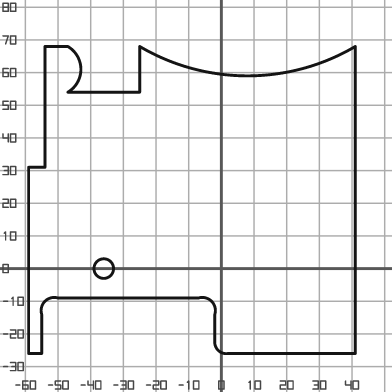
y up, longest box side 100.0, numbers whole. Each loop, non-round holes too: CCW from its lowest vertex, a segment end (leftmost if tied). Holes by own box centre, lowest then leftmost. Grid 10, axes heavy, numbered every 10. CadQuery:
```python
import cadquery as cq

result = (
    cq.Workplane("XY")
    .moveTo(-59.0, -26.0)
    .lineTo(-55.0, -26.0)
    .lineTo(-55.0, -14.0)
    .threePointArc((-54.0, -10.0), (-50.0, -9.0))
    .lineTo(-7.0, -9.0)
    .threePointArc((-3.0, -10.0), (-2.0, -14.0))
    .lineTo(-2.0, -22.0)
    .threePointArc((-1.0, -25.0), (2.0, -26.0))
    .lineTo(41.0, -26.0)
    .lineTo(41.0, 68.0)
    .threePointArc((8.0, 59.0), (-25.0, 68.0))
    .lineTo(-25.0, 54.0)
    .lineTo(-47.0, 54.0)
    .threePointArc((-43.0, 61.0), (-47.0, 68.0))
    .lineTo(-54.0, 68.0)
    .lineTo(-54.0, 31.0)
    .lineTo(-59.0, 31.0)
    .close()
    .moveTo(-36.0, 0.0)
    .circle(3.0)
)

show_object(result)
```